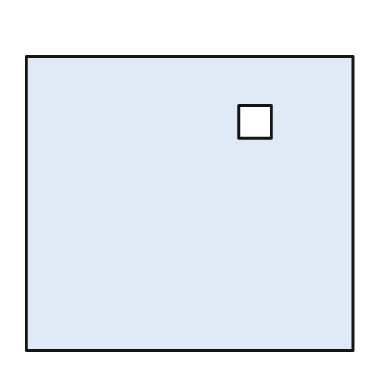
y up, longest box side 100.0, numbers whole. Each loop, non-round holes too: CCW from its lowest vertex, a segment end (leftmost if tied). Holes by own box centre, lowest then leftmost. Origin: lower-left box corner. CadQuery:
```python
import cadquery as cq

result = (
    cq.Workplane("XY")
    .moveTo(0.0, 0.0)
    .lineTo(100.0, 0.0)
    .lineTo(100.0, 90.0)
    .lineTo(0.0, 90.0)
    .close()
    .moveTo(65.0, 65.0)
    .lineTo(75.0, 65.0)
    .lineTo(75.0, 75.0)
    .lineTo(65.0, 75.0)
    .close()
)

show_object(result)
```